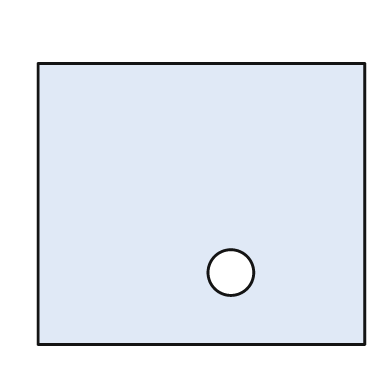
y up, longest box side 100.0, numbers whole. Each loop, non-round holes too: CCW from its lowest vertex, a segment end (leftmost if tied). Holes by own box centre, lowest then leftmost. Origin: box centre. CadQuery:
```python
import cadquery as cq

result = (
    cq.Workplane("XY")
    .moveTo(-50.0, -43.0)
    .lineTo(50.0, -43.0)
    .lineTo(50.0, 43.0)
    .lineTo(-50.0, 43.0)
    .close()
    .moveTo(9.0, -21.0)
    .circle(7.0)
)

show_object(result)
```